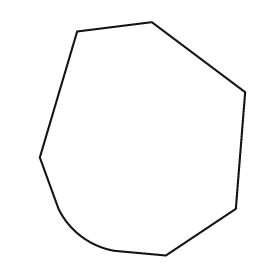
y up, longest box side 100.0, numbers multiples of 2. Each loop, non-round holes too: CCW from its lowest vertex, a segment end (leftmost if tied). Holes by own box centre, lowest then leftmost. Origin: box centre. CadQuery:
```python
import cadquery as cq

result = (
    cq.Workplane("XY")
    .moveTo(10.0, -50.0)
    .lineTo(40.0, -30.0)
    .lineTo(44.0, 20.0)
    .lineTo(4.0, 50.0)
    .lineTo(-28.0, 46.0)
    .lineTo(-44.0, -8.0)
    .lineTo(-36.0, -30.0)
    .threePointArc((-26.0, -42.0), (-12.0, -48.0))
    .close()
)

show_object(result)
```